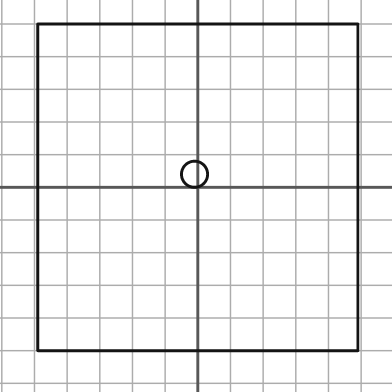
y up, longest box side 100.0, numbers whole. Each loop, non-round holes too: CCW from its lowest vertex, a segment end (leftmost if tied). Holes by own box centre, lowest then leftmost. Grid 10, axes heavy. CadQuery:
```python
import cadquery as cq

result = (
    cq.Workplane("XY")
    .moveTo(-49.0, -50.0)
    .lineTo(49.0, -50.0)
    .lineTo(49.0, 50.0)
    .lineTo(-49.0, 50.0)
    .close()
    .moveTo(-1.0, 4.0)
    .circle(4.0)
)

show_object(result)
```